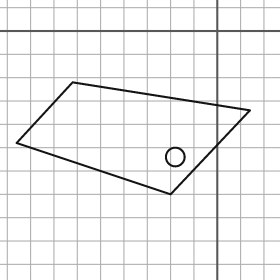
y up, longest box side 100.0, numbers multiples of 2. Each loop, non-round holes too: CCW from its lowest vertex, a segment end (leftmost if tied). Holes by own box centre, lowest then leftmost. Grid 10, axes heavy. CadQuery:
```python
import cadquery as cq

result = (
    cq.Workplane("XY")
    .moveTo(-20.0, -70.0)
    .lineTo(14.0, -34.0)
    .lineTo(-62.0, -22.0)
    .lineTo(-86.0, -48.0)
    .close()
    .moveTo(-18.0, -54.0)
    .circle(4.0)
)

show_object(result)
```